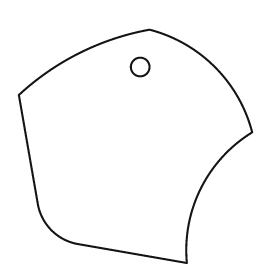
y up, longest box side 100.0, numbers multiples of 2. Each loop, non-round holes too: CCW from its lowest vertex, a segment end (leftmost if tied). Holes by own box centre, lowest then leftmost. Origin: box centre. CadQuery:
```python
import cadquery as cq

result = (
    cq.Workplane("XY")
    .moveTo(22.0, -50.0)
    .threePointArc((28.0, -18.0), (50.0, 6.0))
    .threePointArc((34.0, 34.0), (6.0, 50.0))
    .threePointArc((-24.0, 40.0), (-50.0, 22.0))
    .lineTo(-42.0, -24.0)
    .threePointArc((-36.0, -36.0), (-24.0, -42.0))
    .close()
    .moveTo(2.0, 34.0)
    .circle(4.0)
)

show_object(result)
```